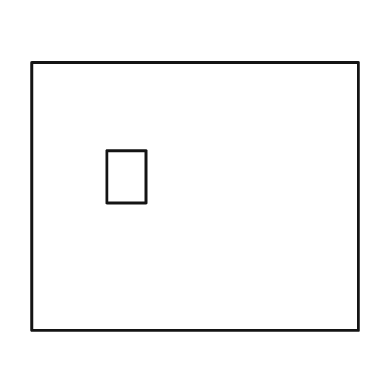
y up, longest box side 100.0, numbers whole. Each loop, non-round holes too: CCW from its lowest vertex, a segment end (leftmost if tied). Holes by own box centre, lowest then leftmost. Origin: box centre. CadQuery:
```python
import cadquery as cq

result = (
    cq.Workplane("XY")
    .moveTo(-50.0, -41.0)
    .lineTo(50.0, -41.0)
    .lineTo(50.0, 41.0)
    .lineTo(-50.0, 41.0)
    .close()
    .moveTo(-27.0, -2.0)
    .lineTo(-15.0, -2.0)
    .lineTo(-15.0, 14.0)
    .lineTo(-27.0, 14.0)
    .close()
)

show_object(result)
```